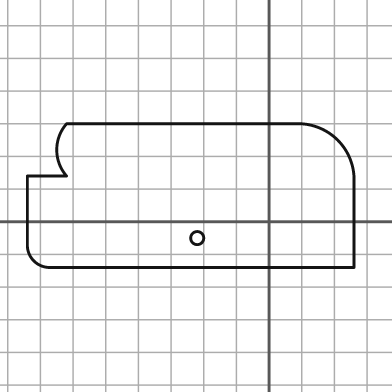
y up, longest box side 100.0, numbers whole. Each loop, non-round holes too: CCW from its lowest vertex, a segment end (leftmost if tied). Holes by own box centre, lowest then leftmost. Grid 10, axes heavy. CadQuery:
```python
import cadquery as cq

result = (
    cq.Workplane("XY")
    .moveTo(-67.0, -14.0)
    .lineTo(26.0, -14.0)
    .lineTo(26.0, 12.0)
    .threePointArc((21.0, 25.0), (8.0, 30.0))
    .lineTo(-62.0, 30.0)
    .threePointArc((-65.0, 22.0), (-62.0, 14.0))
    .lineTo(-74.0, 14.0)
    .lineTo(-74.0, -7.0)
    .threePointArc((-72.0, -12.0), (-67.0, -14.0))
    .close()
    .moveTo(-22.0, -5.0)
    .circle(2.0)
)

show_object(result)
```